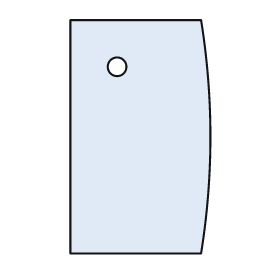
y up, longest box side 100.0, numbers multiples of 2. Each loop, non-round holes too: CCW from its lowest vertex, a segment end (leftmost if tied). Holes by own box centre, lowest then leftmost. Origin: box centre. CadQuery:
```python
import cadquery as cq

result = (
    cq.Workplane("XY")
    .moveTo(-30.0, -50.0)
    .lineTo(26.0, -50.0)
    .threePointArc((30.0, 0.0), (26.0, 50.0))
    .lineTo(-30.0, 50.0)
    .close()
    .moveTo(-10.0, 30.0)
    .circle(4.0)
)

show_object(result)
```